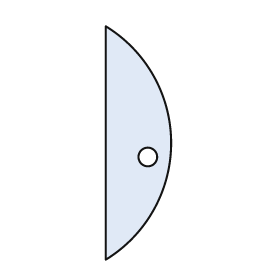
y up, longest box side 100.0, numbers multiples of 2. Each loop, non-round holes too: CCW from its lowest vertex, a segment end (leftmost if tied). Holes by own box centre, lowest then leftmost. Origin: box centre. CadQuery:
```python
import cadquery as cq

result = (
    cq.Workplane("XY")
    .moveTo(-14.0, -50.0)
    .threePointArc((14.0, 0.0), (-14.0, 50.0))
    .close()
    .moveTo(4.0, -6.0)
    .circle(4.0)
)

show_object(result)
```